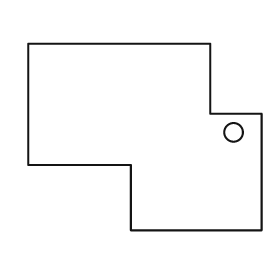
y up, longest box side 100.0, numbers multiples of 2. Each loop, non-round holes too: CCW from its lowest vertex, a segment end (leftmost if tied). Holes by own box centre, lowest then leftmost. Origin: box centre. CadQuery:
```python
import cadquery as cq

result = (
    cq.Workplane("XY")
    .moveTo(-6.0, -40.0)
    .lineTo(50.0, -40.0)
    .lineTo(50.0, 10.0)
    .lineTo(28.0, 10.0)
    .lineTo(28.0, 40.0)
    .lineTo(-50.0, 40.0)
    .lineTo(-50.0, -12.0)
    .lineTo(-6.0, -12.0)
    .close()
    .moveTo(38.0, 2.0)
    .circle(4.0)
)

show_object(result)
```